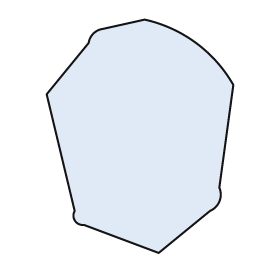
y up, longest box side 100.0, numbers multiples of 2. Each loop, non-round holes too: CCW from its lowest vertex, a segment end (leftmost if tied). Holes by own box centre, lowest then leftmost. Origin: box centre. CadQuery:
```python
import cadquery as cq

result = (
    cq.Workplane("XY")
    .moveTo(8.0, -50.0)
    .lineTo(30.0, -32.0)
    .threePointArc((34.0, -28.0), (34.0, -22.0))
    .lineTo(40.0, 22.0)
    .threePointArc((24.0, 40.0), (2.0, 50.0))
    .lineTo(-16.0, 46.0)
    .threePointArc((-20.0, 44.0), (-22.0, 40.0))
    .lineTo(-40.0, 18.0)
    .lineTo(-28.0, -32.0)
    .threePointArc((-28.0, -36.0), (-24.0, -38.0))
    .close()
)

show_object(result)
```